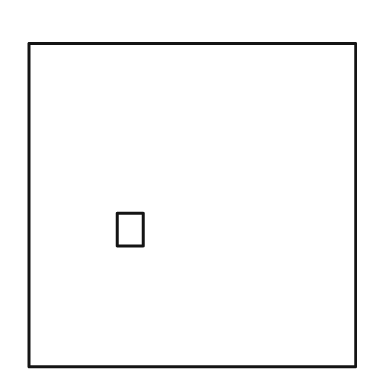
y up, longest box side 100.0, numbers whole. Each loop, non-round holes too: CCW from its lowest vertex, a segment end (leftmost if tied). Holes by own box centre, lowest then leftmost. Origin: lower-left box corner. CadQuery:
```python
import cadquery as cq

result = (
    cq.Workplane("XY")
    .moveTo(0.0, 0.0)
    .lineTo(100.0, 0.0)
    .lineTo(100.0, 99.0)
    .lineTo(0.0, 99.0)
    .close()
    .moveTo(27.0, 37.0)
    .lineTo(35.0, 37.0)
    .lineTo(35.0, 47.0)
    .lineTo(27.0, 47.0)
    .close()
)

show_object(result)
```